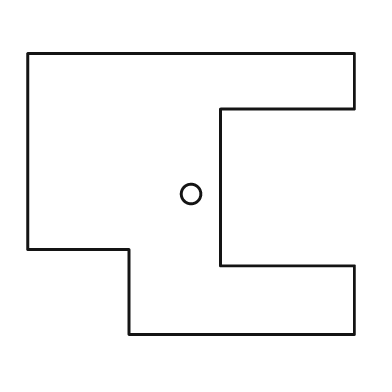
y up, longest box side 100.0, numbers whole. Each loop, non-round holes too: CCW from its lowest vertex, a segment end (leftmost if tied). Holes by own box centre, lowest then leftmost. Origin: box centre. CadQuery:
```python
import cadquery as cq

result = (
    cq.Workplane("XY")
    .moveTo(-19.0, -43.0)
    .lineTo(50.0, -43.0)
    .lineTo(50.0, -22.0)
    .lineTo(9.0, -22.0)
    .lineTo(9.0, 26.0)
    .lineTo(50.0, 26.0)
    .lineTo(50.0, 43.0)
    .lineTo(-50.0, 43.0)
    .lineTo(-50.0, -17.0)
    .lineTo(-19.0, -17.0)
    .close()
    .moveTo(0.0, 0.0)
    .circle(3.0)
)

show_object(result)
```